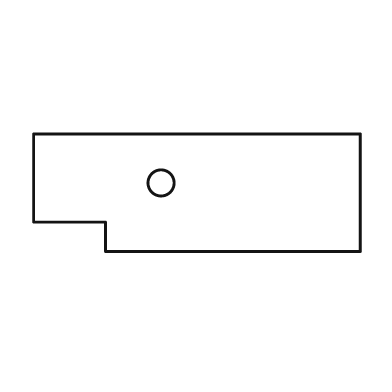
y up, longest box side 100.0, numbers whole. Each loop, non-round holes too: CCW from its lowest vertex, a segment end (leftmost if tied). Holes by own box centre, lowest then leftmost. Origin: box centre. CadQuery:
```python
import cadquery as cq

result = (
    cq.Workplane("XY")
    .moveTo(-28.0, -18.0)
    .lineTo(50.0, -18.0)
    .lineTo(50.0, 18.0)
    .lineTo(-50.0, 18.0)
    .lineTo(-50.0, -9.0)
    .lineTo(-28.0, -9.0)
    .close()
    .moveTo(-11.0, 3.0)
    .circle(4.0)
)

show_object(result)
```